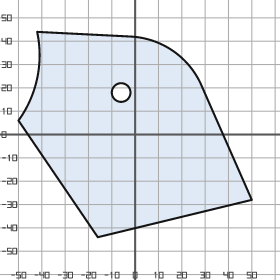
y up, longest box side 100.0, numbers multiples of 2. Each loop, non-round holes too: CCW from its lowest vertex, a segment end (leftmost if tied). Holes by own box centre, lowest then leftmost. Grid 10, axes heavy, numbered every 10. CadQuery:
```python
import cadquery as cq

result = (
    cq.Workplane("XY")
    .moveTo(-16.0, -44.0)
    .lineTo(50.0, -28.0)
    .lineTo(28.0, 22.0)
    .threePointArc((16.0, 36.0), (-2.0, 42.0))
    .lineTo(-42.0, 44.0)
    .threePointArc((-42.0, 24.0), (-50.0, 6.0))
    .close()
    .moveTo(-6.0, 18.0)
    .circle(4.0)
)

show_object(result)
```